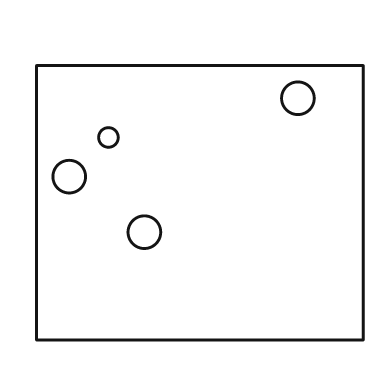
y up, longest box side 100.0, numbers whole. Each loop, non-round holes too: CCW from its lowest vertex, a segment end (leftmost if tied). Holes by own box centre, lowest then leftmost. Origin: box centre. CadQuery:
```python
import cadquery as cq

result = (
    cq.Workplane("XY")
    .moveTo(-50.0, -42.0)
    .lineTo(50.0, -42.0)
    .lineTo(50.0, 42.0)
    .lineTo(-50.0, 42.0)
    .close()
    .moveTo(-17.0, -9.0)
    .circle(5.0)
    .moveTo(-40.0, 8.0)
    .circle(5.0)
    .moveTo(-28.0, 20.0)
    .circle(3.0)
    .moveTo(30.0, 32.0)
    .circle(5.0)
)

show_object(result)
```